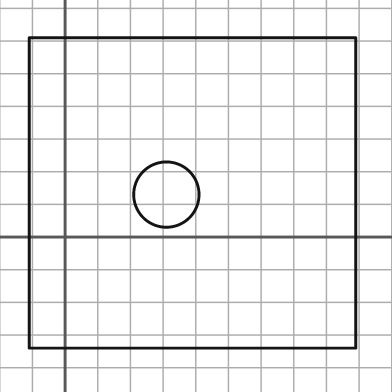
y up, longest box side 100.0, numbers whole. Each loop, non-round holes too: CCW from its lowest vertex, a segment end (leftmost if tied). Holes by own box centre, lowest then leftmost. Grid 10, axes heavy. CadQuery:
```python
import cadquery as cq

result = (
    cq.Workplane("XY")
    .moveTo(-11.0, -34.0)
    .lineTo(89.0, -34.0)
    .lineTo(89.0, 61.0)
    .lineTo(-11.0, 61.0)
    .close()
    .moveTo(31.0, 13.0)
    .circle(10.0)
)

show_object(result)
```